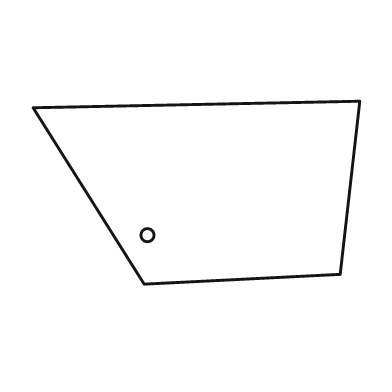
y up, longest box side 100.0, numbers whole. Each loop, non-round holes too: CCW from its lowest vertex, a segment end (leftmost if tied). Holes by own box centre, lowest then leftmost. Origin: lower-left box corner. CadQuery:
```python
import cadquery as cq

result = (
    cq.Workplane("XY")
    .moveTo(34.0, 0.0)
    .lineTo(94.0, 3.0)
    .lineTo(100.0, 56.0)
    .lineTo(0.0, 54.0)
    .close()
    .moveTo(35.0, 15.0)
    .circle(2.0)
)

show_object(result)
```